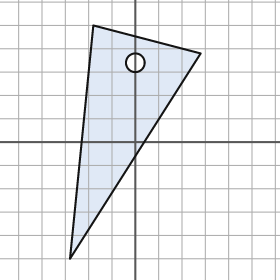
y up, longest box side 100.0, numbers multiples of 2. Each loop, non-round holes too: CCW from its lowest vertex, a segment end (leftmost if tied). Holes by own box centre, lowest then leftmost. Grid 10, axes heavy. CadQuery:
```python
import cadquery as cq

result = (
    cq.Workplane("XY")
    .moveTo(-28.0, -50.0)
    .lineTo(28.0, 38.0)
    .lineTo(-18.0, 50.0)
    .close()
    .moveTo(0.0, 34.0)
    .circle(4.0)
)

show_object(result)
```